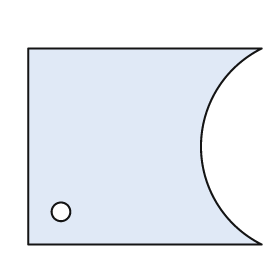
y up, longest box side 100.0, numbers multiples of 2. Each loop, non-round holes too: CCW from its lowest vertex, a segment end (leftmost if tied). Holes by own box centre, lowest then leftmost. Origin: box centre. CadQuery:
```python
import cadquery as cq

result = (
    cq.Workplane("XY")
    .moveTo(-50.0, -42.0)
    .lineTo(50.0, -42.0)
    .threePointArc((24.0, 0.0), (50.0, 42.0))
    .lineTo(-50.0, 42.0)
    .close()
    .moveTo(-36.0, -28.0)
    .circle(4.0)
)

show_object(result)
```